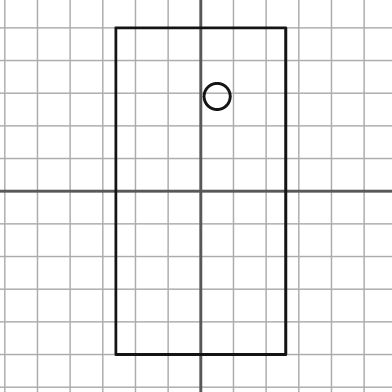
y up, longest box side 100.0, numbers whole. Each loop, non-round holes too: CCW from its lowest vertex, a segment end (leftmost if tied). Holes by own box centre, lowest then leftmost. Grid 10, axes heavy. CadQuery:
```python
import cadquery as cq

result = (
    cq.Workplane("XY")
    .moveTo(-26.0, -50.0)
    .lineTo(26.0, -50.0)
    .lineTo(26.0, 50.0)
    .lineTo(-26.0, 50.0)
    .close()
    .moveTo(5.0, 29.0)
    .circle(4.0)
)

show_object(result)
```